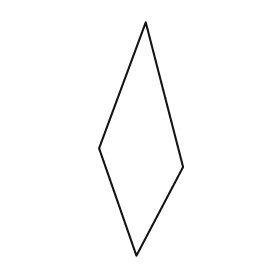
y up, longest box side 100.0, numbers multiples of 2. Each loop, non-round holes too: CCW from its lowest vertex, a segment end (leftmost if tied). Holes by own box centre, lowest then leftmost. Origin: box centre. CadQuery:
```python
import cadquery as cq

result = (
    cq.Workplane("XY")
    .moveTo(-2.0, -50.0)
    .lineTo(18.0, -12.0)
    .lineTo(2.0, 50.0)
    .lineTo(-18.0, -4.0)
    .close()
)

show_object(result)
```